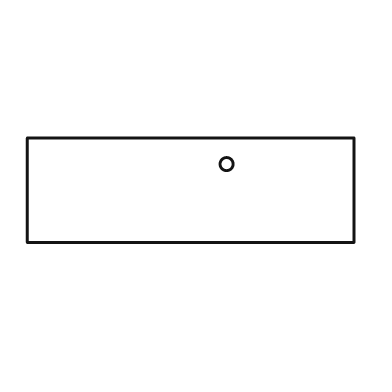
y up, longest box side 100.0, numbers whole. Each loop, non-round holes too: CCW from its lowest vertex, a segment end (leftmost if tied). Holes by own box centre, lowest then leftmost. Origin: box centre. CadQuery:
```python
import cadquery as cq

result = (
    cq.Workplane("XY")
    .moveTo(-50.0, -16.0)
    .lineTo(50.0, -16.0)
    .lineTo(50.0, 16.0)
    .lineTo(-50.0, 16.0)
    .close()
    .moveTo(11.0, 8.0)
    .circle(2.0)
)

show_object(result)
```